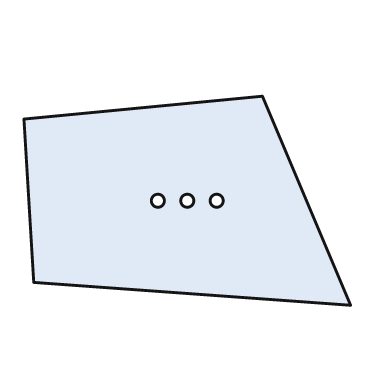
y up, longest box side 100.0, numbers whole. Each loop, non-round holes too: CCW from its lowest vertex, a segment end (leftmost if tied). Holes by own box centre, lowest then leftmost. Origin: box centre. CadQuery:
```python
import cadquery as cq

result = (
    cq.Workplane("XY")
    .moveTo(50.0, -32.0)
    .lineTo(23.0, 32.0)
    .lineTo(-50.0, 25.0)
    .lineTo(-47.0, -25.0)
    .close()
    .moveTo(-9.0, 0.0)
    .circle(2.0)
    .moveTo(0.0, 0.0)
    .circle(2.0)
    .moveTo(9.0, 0.0)
    .circle(2.0)
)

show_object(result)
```